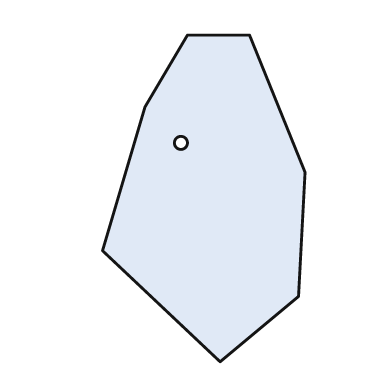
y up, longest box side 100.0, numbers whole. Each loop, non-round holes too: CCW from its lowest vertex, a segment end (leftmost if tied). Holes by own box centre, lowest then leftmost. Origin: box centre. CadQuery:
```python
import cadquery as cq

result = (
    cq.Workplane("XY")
    .moveTo(5.0, -50.0)
    .lineTo(29.0, -30.0)
    .lineTo(31.0, 8.0)
    .lineTo(14.0, 50.0)
    .lineTo(-5.0, 50.0)
    .lineTo(-18.0, 28.0)
    .lineTo(-31.0, -16.0)
    .close()
    .moveTo(-7.0, 17.0)
    .circle(2.0)
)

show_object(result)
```